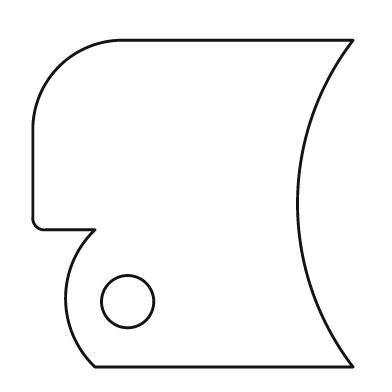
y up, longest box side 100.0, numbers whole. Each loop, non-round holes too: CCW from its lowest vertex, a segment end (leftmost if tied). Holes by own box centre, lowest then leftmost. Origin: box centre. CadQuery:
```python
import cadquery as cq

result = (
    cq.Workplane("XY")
    .moveTo(-30.0, -50.0)
    .lineTo(49.0, -50.0)
    .threePointArc((32.0, 0.0), (49.0, 50.0))
    .lineTo(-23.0, 50.0)
    .threePointArc((-41.0, 42.0), (-49.0, 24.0))
    .lineTo(-49.0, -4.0)
    .threePointArc((-48.0, -7.0), (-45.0, -8.0))
    .lineTo(-30.0, -8.0)
    .threePointArc((-39.0, -29.0), (-30.0, -50.0))
    .close()
    .moveTo(-20.0, -30.0)
    .circle(8.0)
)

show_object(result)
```